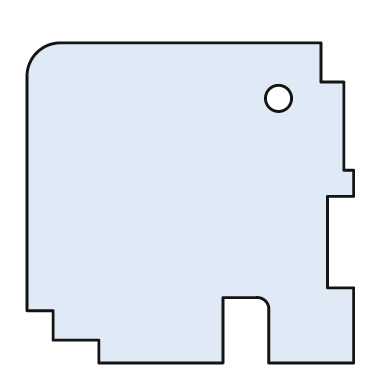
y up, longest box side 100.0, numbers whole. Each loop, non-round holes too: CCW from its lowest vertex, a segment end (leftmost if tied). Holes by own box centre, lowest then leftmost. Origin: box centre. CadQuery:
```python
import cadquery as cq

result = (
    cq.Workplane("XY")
    .moveTo(-28.0, -49.0)
    .lineTo(10.0, -49.0)
    .lineTo(10.0, -29.0)
    .lineTo(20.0, -29.0)
    .threePointArc((23.0, -30.0), (24.0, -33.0))
    .lineTo(24.0, -49.0)
    .lineTo(50.0, -49.0)
    .lineTo(50.0, -26.0)
    .lineTo(42.0, -26.0)
    .lineTo(42.0, 2.0)
    .lineTo(50.0, 2.0)
    .lineTo(50.0, 10.0)
    .lineTo(47.0, 10.0)
    .lineTo(47.0, 37.0)
    .lineTo(40.0, 37.0)
    .lineTo(40.0, 49.0)
    .lineTo(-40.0, 49.0)
    .threePointArc((-47.0, 46.0), (-50.0, 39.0))
    .lineTo(-50.0, -33.0)
    .lineTo(-42.0, -33.0)
    .lineTo(-42.0, -42.0)
    .lineTo(-28.0, -42.0)
    .close()
    .moveTo(27.0, 32.0)
    .circle(4.0)
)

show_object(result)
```